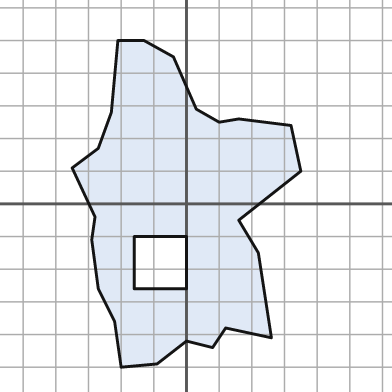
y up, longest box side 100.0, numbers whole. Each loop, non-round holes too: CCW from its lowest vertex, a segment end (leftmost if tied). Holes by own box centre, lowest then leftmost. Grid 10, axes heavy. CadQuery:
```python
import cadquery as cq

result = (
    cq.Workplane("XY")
    .moveTo(-20.0, -50.0)
    .lineTo(-9.0, -49.0)
    .lineTo(0.0, -42.0)
    .lineTo(8.0, -44.0)
    .lineTo(12.0, -38.0)
    .lineTo(26.0, -41.0)
    .lineTo(22.0, -15.0)
    .lineTo(16.0, -5.0)
    .lineTo(35.0, 10.0)
    .lineTo(32.0, 24.0)
    .lineTo(16.0, 26.0)
    .lineTo(10.0, 25.0)
    .lineTo(3.0, 29.0)
    .lineTo(-4.0, 45.0)
    .lineTo(-13.0, 50.0)
    .lineTo(-21.0, 50.0)
    .lineTo(-23.0, 28.0)
    .lineTo(-27.0, 17.0)
    .lineTo(-35.0, 11.0)
    .lineTo(-28.0, -4.0)
    .lineTo(-29.0, -11.0)
    .lineTo(-27.0, -26.0)
    .lineTo(-22.0, -36.0)
    .close()
    .moveTo(-16.0, -26.0)
    .lineTo(0.0, -26.0)
    .lineTo(0.0, -10.0)
    .lineTo(-16.0, -10.0)
    .close()
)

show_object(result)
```